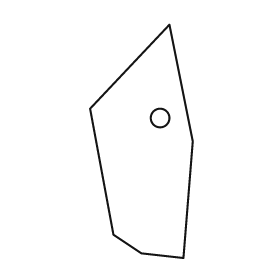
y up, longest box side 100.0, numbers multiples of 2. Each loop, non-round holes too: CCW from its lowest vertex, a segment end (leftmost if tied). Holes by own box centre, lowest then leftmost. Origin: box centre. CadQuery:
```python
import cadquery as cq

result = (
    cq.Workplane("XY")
    .moveTo(18.0, -50.0)
    .lineTo(22.0, 0.0)
    .lineTo(12.0, 50.0)
    .lineTo(-22.0, 14.0)
    .lineTo(-12.0, -40.0)
    .lineTo(0.0, -48.0)
    .close()
    .moveTo(8.0, 10.0)
    .circle(4.0)
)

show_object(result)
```